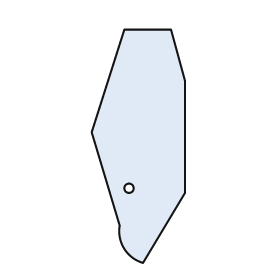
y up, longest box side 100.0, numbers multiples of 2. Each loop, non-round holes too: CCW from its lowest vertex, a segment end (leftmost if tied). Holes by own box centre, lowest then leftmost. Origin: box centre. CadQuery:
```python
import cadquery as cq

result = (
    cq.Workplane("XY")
    .moveTo(2.0, -50.0)
    .lineTo(20.0, -20.0)
    .lineTo(20.0, 28.0)
    .lineTo(14.0, 50.0)
    .lineTo(-6.0, 50.0)
    .lineTo(-20.0, 6.0)
    .lineTo(-8.0, -34.0)
    .threePointArc((-6.0, -44.0), (2.0, -50.0))
    .close()
    .moveTo(-4.0, -18.0)
    .circle(2.0)
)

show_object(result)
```